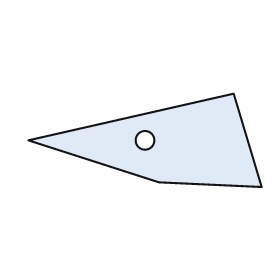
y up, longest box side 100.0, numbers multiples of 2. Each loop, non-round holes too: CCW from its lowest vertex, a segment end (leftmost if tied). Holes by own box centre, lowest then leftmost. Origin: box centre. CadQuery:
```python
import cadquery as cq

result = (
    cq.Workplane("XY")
    .moveTo(50.0, -20.0)
    .lineTo(38.0, 20.0)
    .lineTo(-50.0, 0.0)
    .lineTo(6.0, -18.0)
    .close()
    .moveTo(0.0, 0.0)
    .circle(4.0)
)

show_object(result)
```